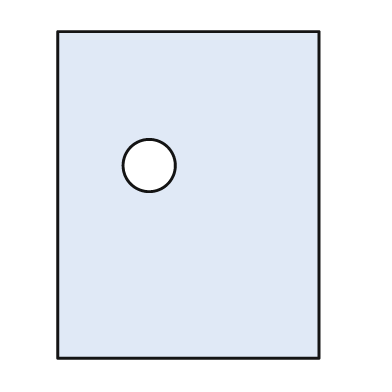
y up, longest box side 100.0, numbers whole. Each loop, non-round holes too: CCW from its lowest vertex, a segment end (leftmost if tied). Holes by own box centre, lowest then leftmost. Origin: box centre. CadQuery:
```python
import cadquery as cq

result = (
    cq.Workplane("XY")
    .moveTo(-40.0, -50.0)
    .lineTo(40.0, -50.0)
    .lineTo(40.0, 50.0)
    .lineTo(-40.0, 50.0)
    .close()
    .moveTo(-12.0, 9.0)
    .circle(8.0)
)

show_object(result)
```